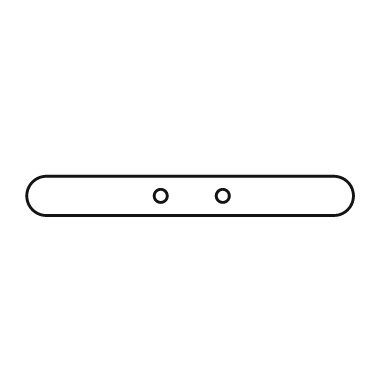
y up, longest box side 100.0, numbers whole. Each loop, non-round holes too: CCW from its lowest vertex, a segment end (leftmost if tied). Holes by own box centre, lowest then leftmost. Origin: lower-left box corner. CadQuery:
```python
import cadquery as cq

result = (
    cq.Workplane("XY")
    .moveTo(6.0, 0.0)
    .lineTo(94.0, 0.0)
    .threePointArc((100.0, 6.0), (94.0, 12.0))
    .lineTo(6.0, 12.0)
    .threePointArc((0.0, 6.0), (6.0, 0.0))
    .close()
    .moveTo(41.0, 6.0)
    .circle(2.0)
    .moveTo(60.0, 6.0)
    .circle(2.0)
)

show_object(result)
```